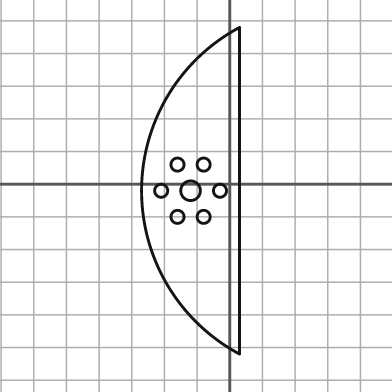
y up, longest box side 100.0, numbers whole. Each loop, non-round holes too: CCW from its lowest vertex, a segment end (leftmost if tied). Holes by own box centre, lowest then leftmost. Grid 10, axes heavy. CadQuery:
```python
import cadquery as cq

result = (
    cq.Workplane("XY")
    .moveTo(3.0, -52.0)
    .lineTo(3.0, 48.0)
    .threePointArc((-27.0, -2.0), (3.0, -52.0))
    .close()
    .moveTo(-16.0, -10.0)
    .circle(2.0)
    .moveTo(-8.0, -10.0)
    .circle(2.0)
    .moveTo(-21.0, -2.0)
    .circle(2.0)
    .moveTo(-12.0, -2.0)
    .circle(3.0)
    .moveTo(-3.0, -2.0)
    .circle(2.0)
    .moveTo(-16.0, 6.0)
    .circle(2.0)
    .moveTo(-8.0, 6.0)
    .circle(2.0)
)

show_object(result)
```